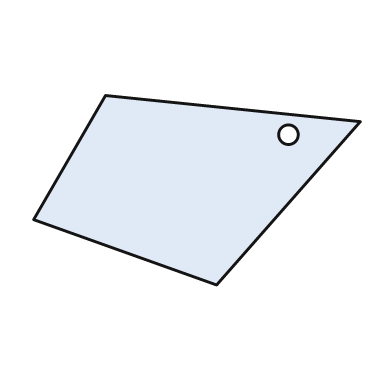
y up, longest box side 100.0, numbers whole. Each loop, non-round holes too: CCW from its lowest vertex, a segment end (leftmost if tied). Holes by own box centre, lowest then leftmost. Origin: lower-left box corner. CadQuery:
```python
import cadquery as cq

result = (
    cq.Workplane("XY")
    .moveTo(56.0, 0.0)
    .lineTo(100.0, 50.0)
    .lineTo(22.0, 58.0)
    .lineTo(0.0, 20.0)
    .close()
    .moveTo(78.0, 46.0)
    .circle(3.0)
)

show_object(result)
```